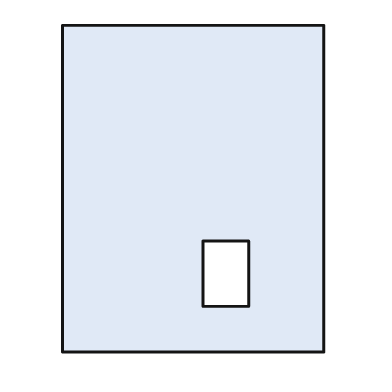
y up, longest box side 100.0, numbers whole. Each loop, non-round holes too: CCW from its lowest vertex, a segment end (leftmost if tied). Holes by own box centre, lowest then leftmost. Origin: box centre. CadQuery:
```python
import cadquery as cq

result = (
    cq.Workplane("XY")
    .moveTo(-40.0, -50.0)
    .lineTo(40.0, -50.0)
    .lineTo(40.0, 50.0)
    .lineTo(-40.0, 50.0)
    .close()
    .moveTo(3.0, -36.0)
    .lineTo(17.0, -36.0)
    .lineTo(17.0, -16.0)
    .lineTo(3.0, -16.0)
    .close()
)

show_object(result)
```